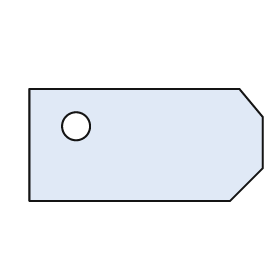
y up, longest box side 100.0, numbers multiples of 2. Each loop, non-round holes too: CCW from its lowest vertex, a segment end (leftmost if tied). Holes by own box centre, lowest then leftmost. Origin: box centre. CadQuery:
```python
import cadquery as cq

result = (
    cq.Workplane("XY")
    .moveTo(-50.0, -24.0)
    .lineTo(36.0, -24.0)
    .lineTo(50.0, -10.0)
    .lineTo(50.0, 12.0)
    .lineTo(40.0, 24.0)
    .lineTo(-50.0, 24.0)
    .close()
    .moveTo(-30.0, 8.0)
    .circle(6.0)
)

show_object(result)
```